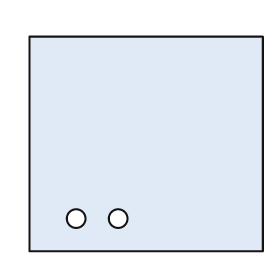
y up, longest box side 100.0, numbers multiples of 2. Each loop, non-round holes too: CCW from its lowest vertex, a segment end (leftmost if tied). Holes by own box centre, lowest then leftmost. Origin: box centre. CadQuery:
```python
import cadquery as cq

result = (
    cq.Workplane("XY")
    .moveTo(-50.0, -46.0)
    .lineTo(50.0, -46.0)
    .lineTo(50.0, 46.0)
    .lineTo(-50.0, 46.0)
    .close()
    .moveTo(-30.0, -32.0)
    .circle(4.0)
    .moveTo(-12.0, -32.0)
    .circle(4.0)
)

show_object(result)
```